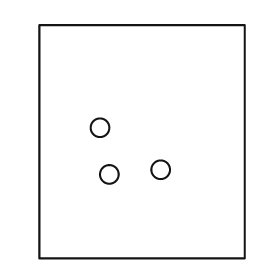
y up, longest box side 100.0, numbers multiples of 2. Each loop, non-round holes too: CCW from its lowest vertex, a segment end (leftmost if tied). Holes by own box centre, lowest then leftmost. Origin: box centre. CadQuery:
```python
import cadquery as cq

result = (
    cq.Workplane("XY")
    .moveTo(-44.0, -50.0)
    .lineTo(44.0, -50.0)
    .lineTo(44.0, 50.0)
    .lineTo(-44.0, 50.0)
    .close()
    .moveTo(-14.0, -14.0)
    .circle(4.0)
    .moveTo(8.0, -12.0)
    .circle(4.0)
    .moveTo(-18.0, 6.0)
    .circle(4.0)
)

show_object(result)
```